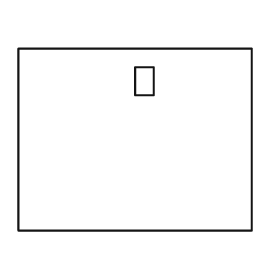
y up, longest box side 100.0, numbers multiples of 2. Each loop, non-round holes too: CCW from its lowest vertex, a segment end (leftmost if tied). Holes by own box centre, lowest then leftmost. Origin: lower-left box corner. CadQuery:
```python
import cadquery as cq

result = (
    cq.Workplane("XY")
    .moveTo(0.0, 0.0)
    .lineTo(100.0, 0.0)
    .lineTo(100.0, 78.0)
    .lineTo(0.0, 78.0)
    .close()
    .moveTo(50.0, 58.0)
    .lineTo(58.0, 58.0)
    .lineTo(58.0, 70.0)
    .lineTo(50.0, 70.0)
    .close()
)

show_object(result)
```